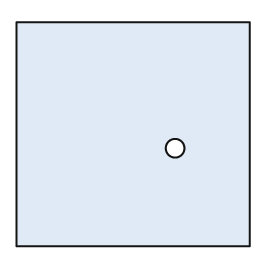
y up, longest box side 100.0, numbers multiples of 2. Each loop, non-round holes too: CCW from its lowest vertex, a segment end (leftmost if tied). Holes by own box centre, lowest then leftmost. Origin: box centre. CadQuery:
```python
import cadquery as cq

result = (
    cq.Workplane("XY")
    .moveTo(-50.0, -48.0)
    .lineTo(50.0, -48.0)
    .lineTo(50.0, 48.0)
    .lineTo(-50.0, 48.0)
    .close()
    .moveTo(18.0, -6.0)
    .circle(4.0)
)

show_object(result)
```